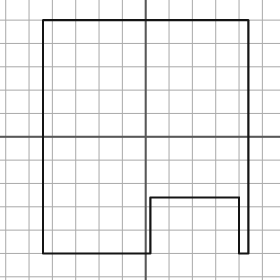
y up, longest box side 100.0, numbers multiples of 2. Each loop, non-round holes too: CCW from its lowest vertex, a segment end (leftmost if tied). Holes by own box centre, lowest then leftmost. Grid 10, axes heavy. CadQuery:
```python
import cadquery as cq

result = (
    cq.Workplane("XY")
    .moveTo(-44.0, -50.0)
    .lineTo(2.0, -50.0)
    .lineTo(2.0, -26.0)
    .lineTo(40.0, -26.0)
    .lineTo(40.0, -50.0)
    .lineTo(44.0, -50.0)
    .lineTo(44.0, 50.0)
    .lineTo(-44.0, 50.0)
    .close()
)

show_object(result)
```